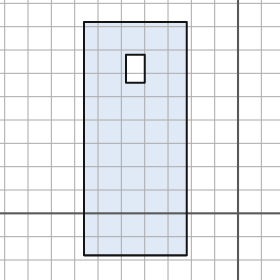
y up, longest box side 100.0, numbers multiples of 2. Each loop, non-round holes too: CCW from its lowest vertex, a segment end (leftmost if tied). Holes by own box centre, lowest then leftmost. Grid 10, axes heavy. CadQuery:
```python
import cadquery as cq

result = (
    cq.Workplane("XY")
    .moveTo(-66.0, -18.0)
    .lineTo(-22.0, -18.0)
    .lineTo(-22.0, 82.0)
    .lineTo(-66.0, 82.0)
    .close()
    .moveTo(-48.0, 56.0)
    .lineTo(-40.0, 56.0)
    .lineTo(-40.0, 68.0)
    .lineTo(-48.0, 68.0)
    .close()
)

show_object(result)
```